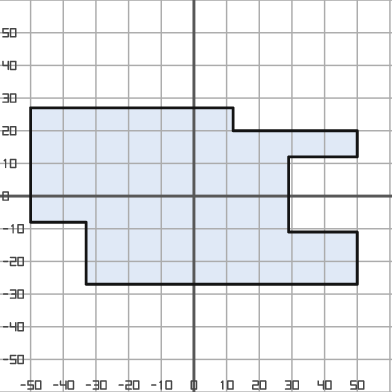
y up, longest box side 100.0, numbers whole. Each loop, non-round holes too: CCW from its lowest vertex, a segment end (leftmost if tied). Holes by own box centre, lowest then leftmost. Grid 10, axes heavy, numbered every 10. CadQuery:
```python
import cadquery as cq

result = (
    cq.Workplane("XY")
    .moveTo(-33.0, -27.0)
    .lineTo(50.0, -27.0)
    .lineTo(50.0, -11.0)
    .lineTo(29.0, -11.0)
    .lineTo(29.0, 12.0)
    .lineTo(50.0, 12.0)
    .lineTo(50.0, 20.0)
    .lineTo(12.0, 20.0)
    .lineTo(12.0, 27.0)
    .lineTo(-50.0, 27.0)
    .lineTo(-50.0, -8.0)
    .lineTo(-33.0, -8.0)
    .close()
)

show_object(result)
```